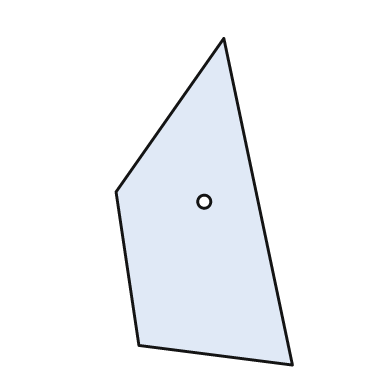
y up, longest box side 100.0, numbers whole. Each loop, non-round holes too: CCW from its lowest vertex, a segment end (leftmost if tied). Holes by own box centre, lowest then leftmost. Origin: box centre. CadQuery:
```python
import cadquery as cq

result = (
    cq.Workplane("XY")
    .moveTo(27.0, -50.0)
    .lineTo(6.0, 50.0)
    .lineTo(-27.0, 3.0)
    .lineTo(-20.0, -44.0)
    .close()
    .moveTo(0.0, 0.0)
    .circle(2.0)
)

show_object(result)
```